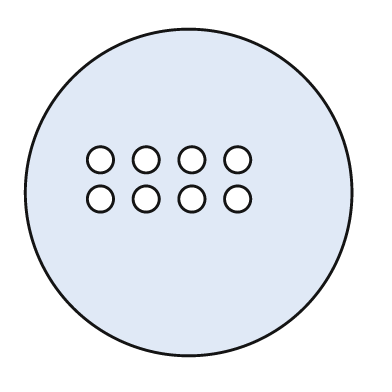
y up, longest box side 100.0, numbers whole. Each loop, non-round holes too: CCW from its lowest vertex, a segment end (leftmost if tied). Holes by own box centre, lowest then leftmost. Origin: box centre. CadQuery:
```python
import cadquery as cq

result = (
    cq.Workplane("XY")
    .moveTo(0.0, 0.0)
    .circle(50.0)
    .moveTo(-27.0, -2.0)
    .circle(4.0)
    .moveTo(-13.0, -2.0)
    .circle(4.0)
    .moveTo(1.0, -2.0)
    .circle(4.0)
    .moveTo(15.0, -2.0)
    .circle(4.0)
    .moveTo(-27.0, 10.0)
    .circle(4.0)
    .moveTo(-13.0, 10.0)
    .circle(4.0)
    .moveTo(1.0, 10.0)
    .circle(4.0)
    .moveTo(15.0, 10.0)
    .circle(4.0)
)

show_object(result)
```